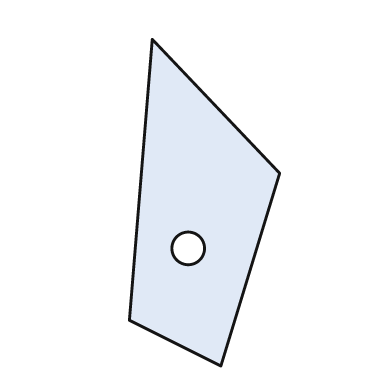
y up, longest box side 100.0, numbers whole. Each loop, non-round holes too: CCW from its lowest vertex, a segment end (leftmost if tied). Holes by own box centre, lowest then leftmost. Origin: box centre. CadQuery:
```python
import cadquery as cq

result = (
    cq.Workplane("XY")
    .moveTo(5.0, -50.0)
    .lineTo(23.0, 9.0)
    .lineTo(-16.0, 50.0)
    .lineTo(-23.0, -36.0)
    .close()
    .moveTo(-5.0, -14.0)
    .circle(5.0)
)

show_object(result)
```